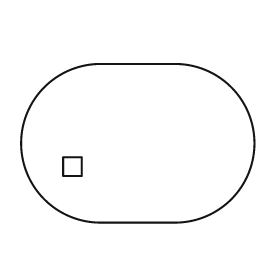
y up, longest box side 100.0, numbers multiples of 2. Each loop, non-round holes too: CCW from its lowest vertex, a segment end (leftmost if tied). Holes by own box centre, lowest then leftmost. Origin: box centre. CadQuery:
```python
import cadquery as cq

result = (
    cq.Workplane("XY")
    .moveTo(-16.0, -34.0)
    .lineTo(16.0, -34.0)
    .threePointArc((50.0, 0.0), (16.0, 34.0))
    .lineTo(-16.0, 34.0)
    .threePointArc((-50.0, 0.0), (-16.0, -34.0))
    .close()
    .moveTo(-32.0, -14.0)
    .lineTo(-24.0, -14.0)
    .lineTo(-24.0, -6.0)
    .lineTo(-32.0, -6.0)
    .close()
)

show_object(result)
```